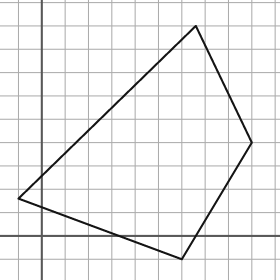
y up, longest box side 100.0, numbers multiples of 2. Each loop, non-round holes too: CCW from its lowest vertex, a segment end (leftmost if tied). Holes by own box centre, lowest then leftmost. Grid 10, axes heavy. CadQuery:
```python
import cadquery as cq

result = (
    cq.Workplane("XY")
    .moveTo(60.0, -10.0)
    .lineTo(90.0, 40.0)
    .lineTo(66.0, 90.0)
    .lineTo(-10.0, 16.0)
    .close()
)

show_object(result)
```